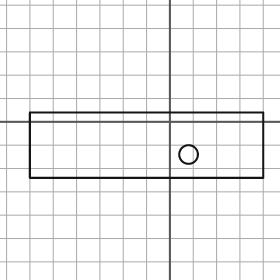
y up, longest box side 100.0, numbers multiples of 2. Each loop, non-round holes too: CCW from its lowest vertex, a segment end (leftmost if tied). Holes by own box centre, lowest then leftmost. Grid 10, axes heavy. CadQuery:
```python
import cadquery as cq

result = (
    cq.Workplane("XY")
    .moveTo(-60.0, -24.0)
    .lineTo(40.0, -24.0)
    .lineTo(40.0, 4.0)
    .lineTo(-60.0, 4.0)
    .close()
    .moveTo(8.0, -14.0)
    .circle(4.0)
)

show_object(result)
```